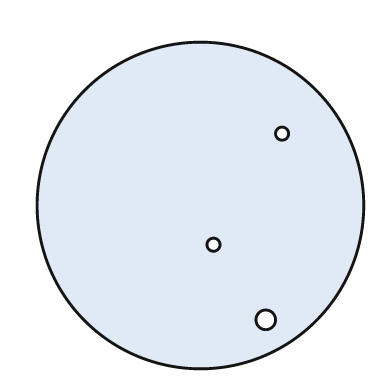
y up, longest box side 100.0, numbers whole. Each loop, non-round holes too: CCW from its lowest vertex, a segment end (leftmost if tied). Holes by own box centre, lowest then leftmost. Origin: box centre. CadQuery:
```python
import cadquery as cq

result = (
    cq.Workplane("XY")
    .moveTo(0.0, 0.0)
    .circle(50.0)
    .moveTo(20.0, -35.0)
    .circle(3.0)
    .moveTo(4.0, -12.0)
    .circle(2.0)
    .moveTo(25.0, 22.0)
    .circle(2.0)
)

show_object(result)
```